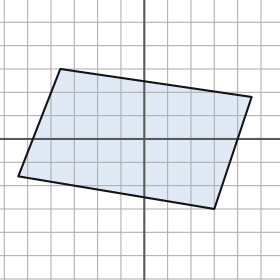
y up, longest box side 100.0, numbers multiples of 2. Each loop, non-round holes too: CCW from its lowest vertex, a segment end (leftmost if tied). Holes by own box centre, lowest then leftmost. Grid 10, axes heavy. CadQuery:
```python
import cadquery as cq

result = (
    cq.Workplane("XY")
    .moveTo(30.0, -30.0)
    .lineTo(46.0, 18.0)
    .lineTo(-36.0, 30.0)
    .lineTo(-54.0, -16.0)
    .close()
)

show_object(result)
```